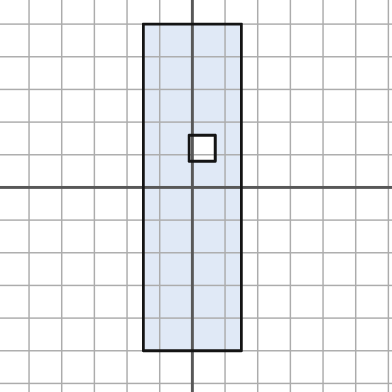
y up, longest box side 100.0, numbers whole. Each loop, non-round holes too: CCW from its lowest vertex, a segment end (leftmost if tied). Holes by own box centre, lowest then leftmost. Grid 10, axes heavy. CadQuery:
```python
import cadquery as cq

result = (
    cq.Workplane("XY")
    .moveTo(-15.0, -50.0)
    .lineTo(15.0, -50.0)
    .lineTo(15.0, 50.0)
    .lineTo(-15.0, 50.0)
    .close()
    .moveTo(-1.0, 8.0)
    .lineTo(7.0, 8.0)
    .lineTo(7.0, 16.0)
    .lineTo(-1.0, 16.0)
    .close()
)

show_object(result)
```